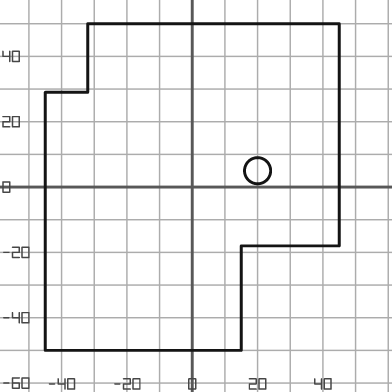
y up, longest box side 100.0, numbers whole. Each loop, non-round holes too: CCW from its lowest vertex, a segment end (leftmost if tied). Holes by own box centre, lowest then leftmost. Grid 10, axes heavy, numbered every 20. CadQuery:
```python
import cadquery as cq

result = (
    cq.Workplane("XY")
    .moveTo(-45.0, -50.0)
    .lineTo(15.0, -50.0)
    .lineTo(15.0, -18.0)
    .lineTo(45.0, -18.0)
    .lineTo(45.0, 50.0)
    .lineTo(-32.0, 50.0)
    .lineTo(-32.0, 29.0)
    .lineTo(-45.0, 29.0)
    .close()
    .moveTo(20.0, 5.0)
    .circle(4.0)
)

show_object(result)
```